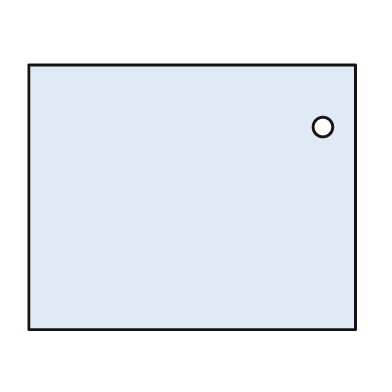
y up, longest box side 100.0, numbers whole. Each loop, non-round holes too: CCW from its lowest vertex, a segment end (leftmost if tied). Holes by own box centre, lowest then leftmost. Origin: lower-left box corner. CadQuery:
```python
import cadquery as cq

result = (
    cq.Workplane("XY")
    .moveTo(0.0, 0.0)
    .lineTo(100.0, 0.0)
    .lineTo(100.0, 81.0)
    .lineTo(0.0, 81.0)
    .close()
    .moveTo(90.0, 62.0)
    .circle(3.0)
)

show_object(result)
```